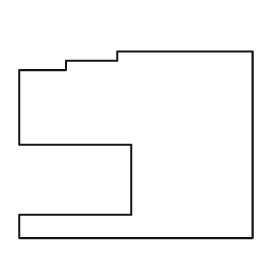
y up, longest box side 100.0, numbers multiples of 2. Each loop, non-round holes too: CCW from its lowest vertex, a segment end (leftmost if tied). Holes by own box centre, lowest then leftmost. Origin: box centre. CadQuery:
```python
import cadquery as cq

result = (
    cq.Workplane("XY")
    .moveTo(-50.0, -40.0)
    .lineTo(50.0, -40.0)
    .lineTo(50.0, 40.0)
    .lineTo(-8.0, 40.0)
    .lineTo(-8.0, 36.0)
    .lineTo(-30.0, 36.0)
    .lineTo(-30.0, 32.0)
    .lineTo(-50.0, 32.0)
    .lineTo(-50.0, 0.0)
    .lineTo(-2.0, 0.0)
    .lineTo(-2.0, -30.0)
    .lineTo(-50.0, -30.0)
    .close()
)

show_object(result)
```